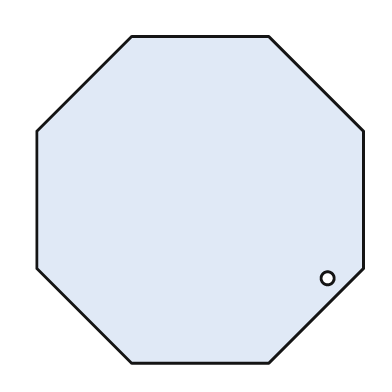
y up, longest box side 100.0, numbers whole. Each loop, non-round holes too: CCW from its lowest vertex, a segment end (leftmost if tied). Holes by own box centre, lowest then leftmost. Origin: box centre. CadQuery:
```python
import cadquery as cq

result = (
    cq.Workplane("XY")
    .moveTo(-21.0, -50.0)
    .lineTo(21.0, -50.0)
    .lineTo(50.0, -21.0)
    .lineTo(50.0, 21.0)
    .lineTo(21.0, 50.0)
    .lineTo(-21.0, 50.0)
    .lineTo(-50.0, 21.0)
    .lineTo(-50.0, -21.0)
    .close()
    .moveTo(39.0, -24.0)
    .circle(2.0)
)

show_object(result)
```